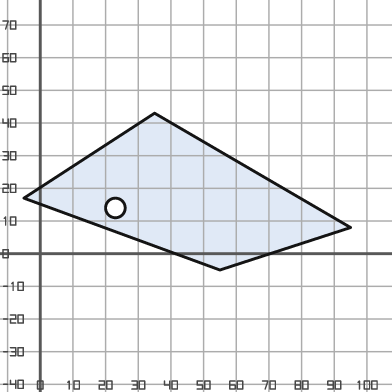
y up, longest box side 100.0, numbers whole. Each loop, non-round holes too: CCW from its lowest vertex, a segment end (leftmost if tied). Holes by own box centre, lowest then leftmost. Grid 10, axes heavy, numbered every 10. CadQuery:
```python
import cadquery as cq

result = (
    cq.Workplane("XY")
    .moveTo(55.0, -5.0)
    .lineTo(95.0, 8.0)
    .lineTo(35.0, 43.0)
    .lineTo(-5.0, 17.0)
    .close()
    .moveTo(23.0, 14.0)
    .circle(3.0)
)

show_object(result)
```